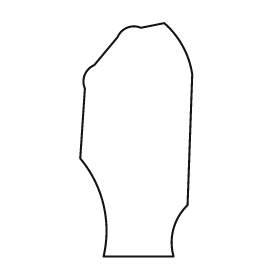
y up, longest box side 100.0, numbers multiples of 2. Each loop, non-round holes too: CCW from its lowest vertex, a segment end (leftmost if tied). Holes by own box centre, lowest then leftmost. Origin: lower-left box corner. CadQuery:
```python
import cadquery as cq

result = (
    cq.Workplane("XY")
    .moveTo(10.0, 0.0)
    .lineTo(40.0, 0.0)
    .threePointArc((40.0, 12.0), (46.0, 22.0))
    .lineTo(48.0, 78.0)
    .threePointArc((44.0, 90.0), (36.0, 100.0))
    .lineTo(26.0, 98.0)
    .threePointArc((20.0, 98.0), (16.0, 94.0))
    .lineTo(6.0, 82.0)
    .threePointArc((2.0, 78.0), (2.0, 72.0))
    .lineTo(0.0, 42.0)
    .threePointArc((10.0, 22.0), (10.0, 0.0))
    .close()
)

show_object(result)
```